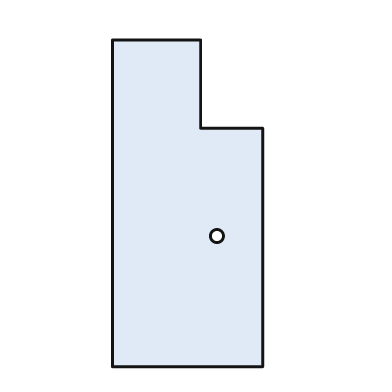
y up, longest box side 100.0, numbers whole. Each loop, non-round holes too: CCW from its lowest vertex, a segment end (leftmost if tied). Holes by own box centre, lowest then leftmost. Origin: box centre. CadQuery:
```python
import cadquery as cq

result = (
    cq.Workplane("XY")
    .moveTo(-23.0, -50.0)
    .lineTo(23.0, -50.0)
    .lineTo(23.0, 23.0)
    .lineTo(4.0, 23.0)
    .lineTo(4.0, 50.0)
    .lineTo(-23.0, 50.0)
    .close()
    .moveTo(9.0, -10.0)
    .circle(2.0)
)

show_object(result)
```